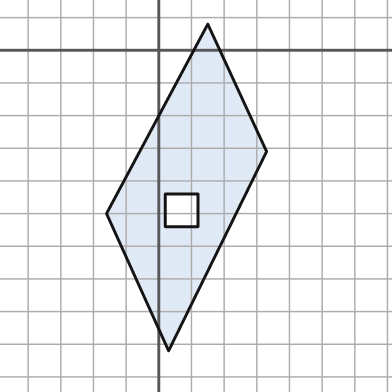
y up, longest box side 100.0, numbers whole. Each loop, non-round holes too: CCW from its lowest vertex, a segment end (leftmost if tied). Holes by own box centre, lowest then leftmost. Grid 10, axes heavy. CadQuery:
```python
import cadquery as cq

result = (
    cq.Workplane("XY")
    .moveTo(3.0, -92.0)
    .lineTo(33.0, -31.0)
    .lineTo(15.0, 8.0)
    .lineTo(-16.0, -50.0)
    .close()
    .moveTo(2.0, -54.0)
    .lineTo(12.0, -54.0)
    .lineTo(12.0, -44.0)
    .lineTo(2.0, -44.0)
    .close()
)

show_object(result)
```